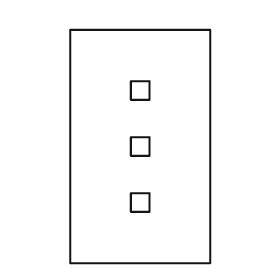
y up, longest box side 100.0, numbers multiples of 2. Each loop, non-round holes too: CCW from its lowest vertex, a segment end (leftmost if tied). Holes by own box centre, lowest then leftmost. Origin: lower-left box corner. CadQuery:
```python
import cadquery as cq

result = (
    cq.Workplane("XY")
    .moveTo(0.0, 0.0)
    .lineTo(60.0, 0.0)
    .lineTo(60.0, 100.0)
    .lineTo(0.0, 100.0)
    .close()
    .moveTo(26.0, 22.0)
    .lineTo(34.0, 22.0)
    .lineTo(34.0, 30.0)
    .lineTo(26.0, 30.0)
    .close()
    .moveTo(26.0, 46.0)
    .lineTo(34.0, 46.0)
    .lineTo(34.0, 54.0)
    .lineTo(26.0, 54.0)
    .close()
    .moveTo(26.0, 70.0)
    .lineTo(34.0, 70.0)
    .lineTo(34.0, 78.0)
    .lineTo(26.0, 78.0)
    .close()
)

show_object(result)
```